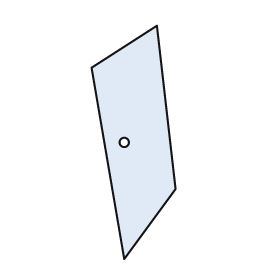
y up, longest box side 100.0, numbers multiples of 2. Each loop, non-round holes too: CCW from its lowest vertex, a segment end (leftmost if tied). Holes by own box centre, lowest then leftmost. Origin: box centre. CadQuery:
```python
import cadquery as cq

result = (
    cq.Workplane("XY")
    .moveTo(-4.0, -50.0)
    .lineTo(18.0, -20.0)
    .lineTo(10.0, 50.0)
    .lineTo(-18.0, 32.0)
    .close()
    .moveTo(-4.0, 0.0)
    .circle(2.0)
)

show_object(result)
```